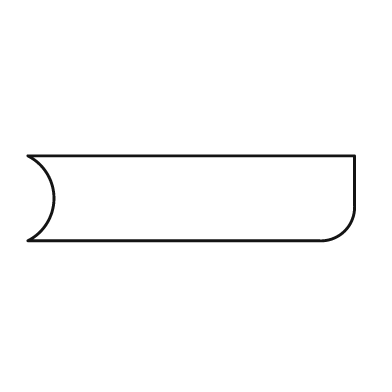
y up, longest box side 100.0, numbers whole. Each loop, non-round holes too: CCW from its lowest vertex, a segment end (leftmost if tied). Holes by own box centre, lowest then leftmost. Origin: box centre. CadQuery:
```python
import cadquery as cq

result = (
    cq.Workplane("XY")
    .moveTo(-50.0, -13.0)
    .lineTo(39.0, -13.0)
    .threePointArc((47.0, -10.0), (50.0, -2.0))
    .lineTo(50.0, 13.0)
    .lineTo(-50.0, 13.0)
    .threePointArc((-42.0, 0.0), (-50.0, -13.0))
    .close()
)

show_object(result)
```